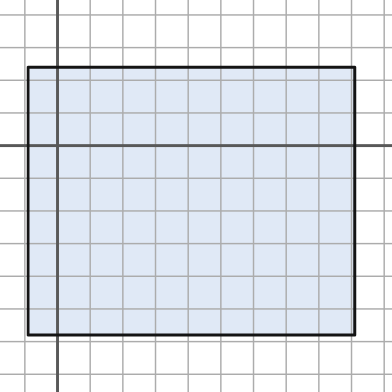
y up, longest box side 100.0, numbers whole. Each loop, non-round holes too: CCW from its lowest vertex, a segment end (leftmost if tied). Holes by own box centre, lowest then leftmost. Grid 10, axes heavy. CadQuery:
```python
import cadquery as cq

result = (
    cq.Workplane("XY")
    .moveTo(-9.0, -58.0)
    .lineTo(91.0, -58.0)
    .lineTo(91.0, 24.0)
    .lineTo(-9.0, 24.0)
    .close()
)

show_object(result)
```